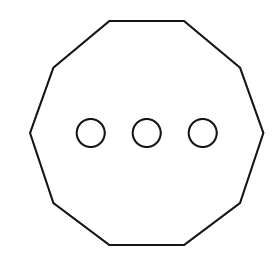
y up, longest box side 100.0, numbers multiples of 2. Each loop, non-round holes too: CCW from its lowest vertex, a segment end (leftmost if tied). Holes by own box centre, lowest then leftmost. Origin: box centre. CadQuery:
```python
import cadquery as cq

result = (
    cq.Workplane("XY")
    .moveTo(-16.0, -48.0)
    .lineTo(16.0, -48.0)
    .lineTo(40.0, -30.0)
    .lineTo(50.0, 0.0)
    .lineTo(40.0, 28.0)
    .lineTo(16.0, 48.0)
    .lineTo(-16.0, 48.0)
    .lineTo(-40.0, 28.0)
    .lineTo(-50.0, 0.0)
    .lineTo(-40.0, -30.0)
    .close()
    .moveTo(-24.0, 0.0)
    .circle(6.0)
    .moveTo(0.0, 0.0)
    .circle(6.0)
    .moveTo(24.0, 0.0)
    .circle(6.0)
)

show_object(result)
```